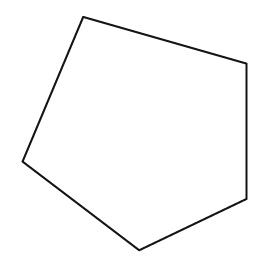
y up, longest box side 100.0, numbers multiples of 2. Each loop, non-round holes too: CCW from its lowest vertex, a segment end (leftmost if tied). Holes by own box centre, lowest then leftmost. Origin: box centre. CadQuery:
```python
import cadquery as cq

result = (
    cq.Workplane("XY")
    .moveTo(2.0, -50.0)
    .lineTo(48.0, -28.0)
    .lineTo(48.0, 30.0)
    .lineTo(-22.0, 50.0)
    .lineTo(-48.0, -12.0)
    .close()
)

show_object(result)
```